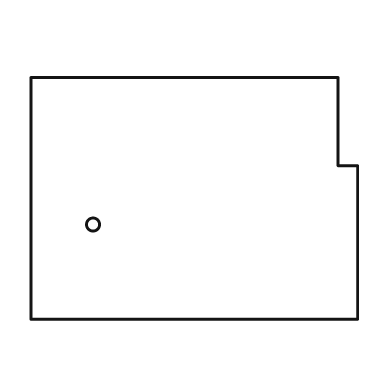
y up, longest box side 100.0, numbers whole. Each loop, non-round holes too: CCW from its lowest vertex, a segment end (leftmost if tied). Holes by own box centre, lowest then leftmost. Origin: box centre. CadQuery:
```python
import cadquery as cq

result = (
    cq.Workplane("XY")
    .moveTo(-50.0, -37.0)
    .lineTo(50.0, -37.0)
    .lineTo(50.0, 10.0)
    .lineTo(44.0, 10.0)
    .lineTo(44.0, 37.0)
    .lineTo(-50.0, 37.0)
    .close()
    .moveTo(-31.0, -8.0)
    .circle(2.0)
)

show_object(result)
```